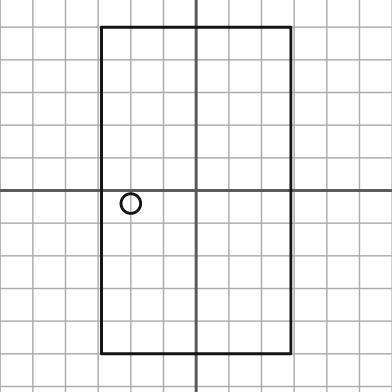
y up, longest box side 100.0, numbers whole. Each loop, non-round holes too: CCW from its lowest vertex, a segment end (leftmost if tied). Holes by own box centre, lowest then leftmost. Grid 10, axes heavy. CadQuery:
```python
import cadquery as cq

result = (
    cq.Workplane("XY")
    .moveTo(-29.0, -50.0)
    .lineTo(29.0, -50.0)
    .lineTo(29.0, 50.0)
    .lineTo(-29.0, 50.0)
    .close()
    .moveTo(-20.0, -4.0)
    .circle(3.0)
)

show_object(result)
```